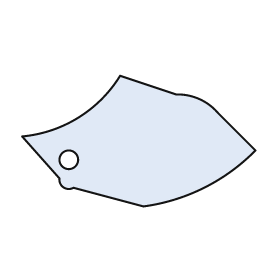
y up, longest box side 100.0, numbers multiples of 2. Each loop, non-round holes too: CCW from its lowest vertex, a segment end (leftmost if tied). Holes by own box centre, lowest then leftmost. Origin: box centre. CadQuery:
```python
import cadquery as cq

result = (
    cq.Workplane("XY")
    .moveTo(2.0, -28.0)
    .threePointArc((28.0, -20.0), (50.0, -4.0))
    .lineTo(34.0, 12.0)
    .threePointArc((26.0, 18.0), (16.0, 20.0))
    .lineTo(-8.0, 28.0)
    .threePointArc((-26.0, 10.0), (-50.0, 2.0))
    .lineTo(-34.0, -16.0)
    .threePointArc((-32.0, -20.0), (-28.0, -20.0))
    .close()
    .moveTo(-30.0, -8.0)
    .circle(4.0)
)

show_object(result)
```